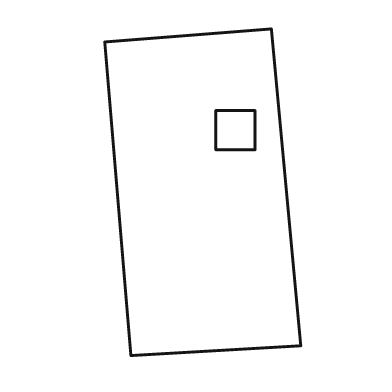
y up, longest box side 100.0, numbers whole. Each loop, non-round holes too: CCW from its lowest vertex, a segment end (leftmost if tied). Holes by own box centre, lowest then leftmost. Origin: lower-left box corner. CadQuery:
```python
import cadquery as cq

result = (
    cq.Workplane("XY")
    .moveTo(8.0, 0.0)
    .lineTo(60.0, 3.0)
    .lineTo(51.0, 100.0)
    .lineTo(0.0, 96.0)
    .close()
    .moveTo(34.0, 63.0)
    .lineTo(46.0, 63.0)
    .lineTo(46.0, 75.0)
    .lineTo(34.0, 75.0)
    .close()
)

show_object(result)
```